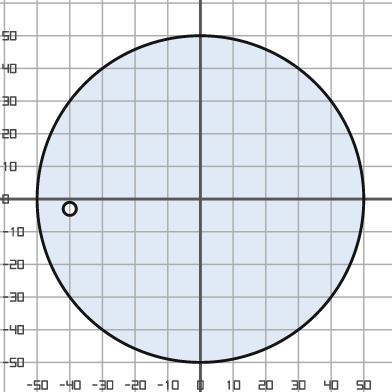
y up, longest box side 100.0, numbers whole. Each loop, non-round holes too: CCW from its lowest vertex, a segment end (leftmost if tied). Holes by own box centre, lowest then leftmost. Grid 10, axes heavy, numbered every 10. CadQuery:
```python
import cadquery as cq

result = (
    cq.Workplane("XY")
    .moveTo(0.0, 0.0)
    .circle(50.0)
    .moveTo(-40.0, -3.0)
    .circle(2.0)
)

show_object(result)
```